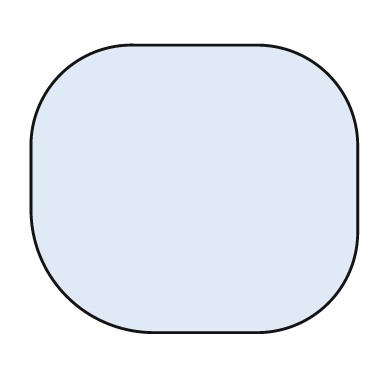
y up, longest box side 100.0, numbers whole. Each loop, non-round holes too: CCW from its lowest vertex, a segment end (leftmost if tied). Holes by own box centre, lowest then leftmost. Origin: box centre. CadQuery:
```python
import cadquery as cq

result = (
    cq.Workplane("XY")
    .moveTo(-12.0, -44.0)
    .lineTo(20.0, -44.0)
    .threePointArc((41.0, -35.0), (50.0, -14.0))
    .lineTo(50.0, 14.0)
    .threePointArc((41.0, 35.0), (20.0, 44.0))
    .lineTo(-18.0, 44.0)
    .threePointArc((-41.0, 35.0), (-50.0, 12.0))
    .lineTo(-50.0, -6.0)
    .threePointArc((-39.0, -33.0), (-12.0, -44.0))
    .close()
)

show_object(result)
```